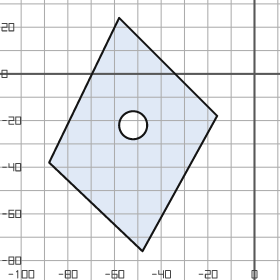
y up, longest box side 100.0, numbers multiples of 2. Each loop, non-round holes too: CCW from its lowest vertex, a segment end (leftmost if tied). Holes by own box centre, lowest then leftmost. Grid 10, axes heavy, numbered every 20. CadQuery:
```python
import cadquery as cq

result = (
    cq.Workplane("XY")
    .moveTo(-48.0, -76.0)
    .lineTo(-16.0, -18.0)
    .lineTo(-58.0, 24.0)
    .lineTo(-88.0, -38.0)
    .close()
    .moveTo(-52.0, -22.0)
    .circle(6.0)
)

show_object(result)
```